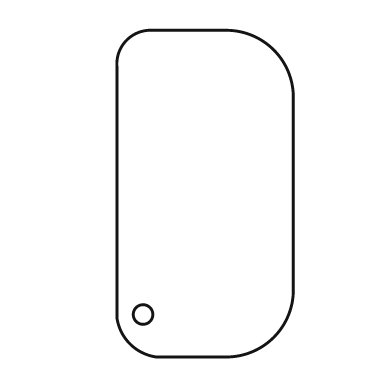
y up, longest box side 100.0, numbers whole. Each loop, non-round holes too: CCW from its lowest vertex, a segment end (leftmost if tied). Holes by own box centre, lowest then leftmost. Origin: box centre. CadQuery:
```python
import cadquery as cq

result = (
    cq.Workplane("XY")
    .moveTo(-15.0, -50.0)
    .lineTo(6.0, -50.0)
    .threePointArc((21.0, -44.0), (27.0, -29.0))
    .lineTo(27.0, 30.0)
    .threePointArc((21.0, 44.0), (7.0, 50.0))
    .lineTo(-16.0, 50.0)
    .threePointArc((-24.0, 47.0), (-27.0, 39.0))
    .lineTo(-27.0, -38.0)
    .threePointArc((-23.0, -46.0), (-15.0, -50.0))
    .close()
    .moveTo(-19.0, -37.0)
    .circle(3.0)
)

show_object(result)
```